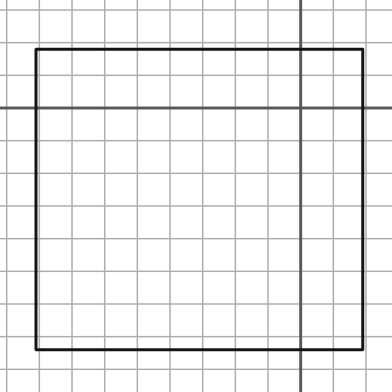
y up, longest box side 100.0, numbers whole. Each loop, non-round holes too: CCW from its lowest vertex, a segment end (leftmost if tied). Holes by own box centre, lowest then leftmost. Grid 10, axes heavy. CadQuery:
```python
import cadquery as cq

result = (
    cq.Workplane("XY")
    .moveTo(-81.0, -74.0)
    .lineTo(19.0, -74.0)
    .lineTo(19.0, 18.0)
    .lineTo(-81.0, 18.0)
    .close()
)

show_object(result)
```